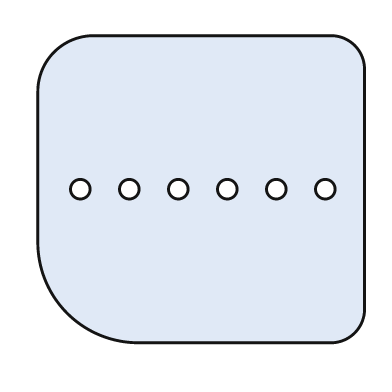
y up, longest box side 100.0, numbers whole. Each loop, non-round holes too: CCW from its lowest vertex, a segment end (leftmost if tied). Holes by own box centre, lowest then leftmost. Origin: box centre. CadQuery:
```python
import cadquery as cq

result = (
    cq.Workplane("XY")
    .moveTo(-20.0, -47.0)
    .lineTo(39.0, -47.0)
    .threePointArc((47.0, -44.0), (50.0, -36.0))
    .lineTo(50.0, 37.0)
    .threePointArc((47.0, 44.0), (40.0, 47.0))
    .lineTo(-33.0, 47.0)
    .threePointArc((-45.0, 42.0), (-50.0, 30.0))
    .lineTo(-50.0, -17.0)
    .threePointArc((-41.0, -38.0), (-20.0, -47.0))
    .close()
    .moveTo(-37.0, 0.0)
    .circle(3.0)
    .moveTo(-22.0, 0.0)
    .circle(3.0)
    .moveTo(-7.0, 0.0)
    .circle(3.0)
    .moveTo(8.0, 0.0)
    .circle(3.0)
    .moveTo(23.0, 0.0)
    .circle(3.0)
    .moveTo(38.0, 0.0)
    .circle(3.0)
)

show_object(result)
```